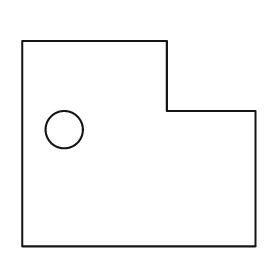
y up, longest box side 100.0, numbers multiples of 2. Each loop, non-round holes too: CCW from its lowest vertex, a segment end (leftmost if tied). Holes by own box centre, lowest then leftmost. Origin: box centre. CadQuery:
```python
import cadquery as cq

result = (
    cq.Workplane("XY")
    .moveTo(-50.0, -44.0)
    .lineTo(50.0, -44.0)
    .lineTo(50.0, 14.0)
    .lineTo(12.0, 14.0)
    .lineTo(12.0, 44.0)
    .lineTo(-50.0, 44.0)
    .close()
    .moveTo(-32.0, 6.0)
    .circle(8.0)
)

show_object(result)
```